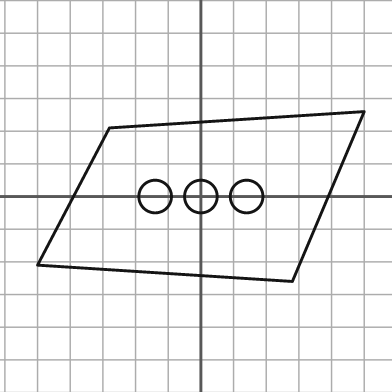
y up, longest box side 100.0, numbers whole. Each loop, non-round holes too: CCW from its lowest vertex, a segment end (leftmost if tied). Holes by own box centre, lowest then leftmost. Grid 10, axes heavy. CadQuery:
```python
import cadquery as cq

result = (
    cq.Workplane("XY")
    .moveTo(28.0, -26.0)
    .lineTo(50.0, 26.0)
    .lineTo(-28.0, 21.0)
    .lineTo(-50.0, -21.0)
    .close()
    .moveTo(-14.0, 0.0)
    .circle(5.0)
    .moveTo(0.0, 0.0)
    .circle(5.0)
    .moveTo(14.0, 0.0)
    .circle(5.0)
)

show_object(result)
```